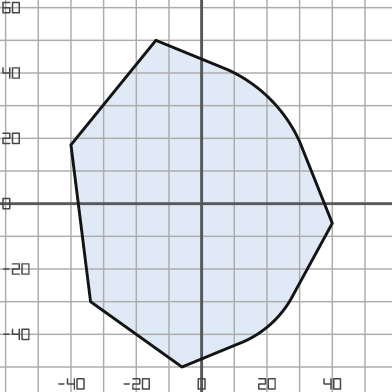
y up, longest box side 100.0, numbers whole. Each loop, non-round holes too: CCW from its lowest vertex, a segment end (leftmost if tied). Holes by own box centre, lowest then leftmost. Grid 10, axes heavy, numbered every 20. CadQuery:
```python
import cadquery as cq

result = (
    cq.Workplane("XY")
    .moveTo(-6.0, -50.0)
    .lineTo(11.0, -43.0)
    .threePointArc((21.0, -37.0), (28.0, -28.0))
    .lineTo(40.0, -6.0)
    .lineTo(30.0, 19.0)
    .threePointArc((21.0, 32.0), (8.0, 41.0))
    .lineTo(-14.0, 50.0)
    .lineTo(-40.0, 18.0)
    .lineTo(-34.0, -30.0)
    .close()
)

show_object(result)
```